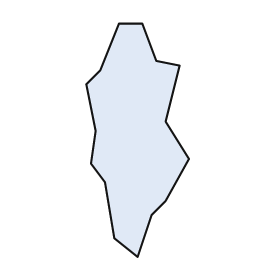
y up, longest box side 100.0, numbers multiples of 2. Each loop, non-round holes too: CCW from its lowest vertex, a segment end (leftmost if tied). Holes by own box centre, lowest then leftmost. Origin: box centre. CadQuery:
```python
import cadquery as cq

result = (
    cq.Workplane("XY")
    .moveTo(0.0, -50.0)
    .lineTo(6.0, -32.0)
    .lineTo(12.0, -26.0)
    .lineTo(22.0, -8.0)
    .lineTo(12.0, 8.0)
    .lineTo(18.0, 32.0)
    .lineTo(8.0, 34.0)
    .lineTo(2.0, 50.0)
    .lineTo(-8.0, 50.0)
    .lineTo(-16.0, 30.0)
    .lineTo(-22.0, 24.0)
    .lineTo(-18.0, 4.0)
    .lineTo(-20.0, -10.0)
    .lineTo(-14.0, -18.0)
    .lineTo(-10.0, -42.0)
    .close()
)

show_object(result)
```